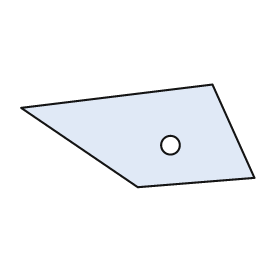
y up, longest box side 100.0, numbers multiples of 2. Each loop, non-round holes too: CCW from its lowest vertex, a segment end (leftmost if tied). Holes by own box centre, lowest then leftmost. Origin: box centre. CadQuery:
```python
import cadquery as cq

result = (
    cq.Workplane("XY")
    .moveTo(0.0, -22.0)
    .lineTo(50.0, -18.0)
    .lineTo(32.0, 22.0)
    .lineTo(-50.0, 12.0)
    .close()
    .moveTo(14.0, -4.0)
    .circle(4.0)
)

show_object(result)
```